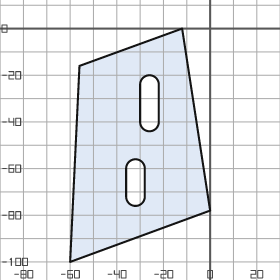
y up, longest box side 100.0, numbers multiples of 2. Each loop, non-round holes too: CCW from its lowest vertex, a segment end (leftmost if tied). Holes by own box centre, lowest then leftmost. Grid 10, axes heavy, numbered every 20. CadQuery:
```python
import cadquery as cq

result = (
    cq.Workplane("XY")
    .moveTo(-60.0, -100.0)
    .lineTo(0.0, -78.0)
    .lineTo(-12.0, 0.0)
    .lineTo(-56.0, -16.0)
    .close()
    .moveTo(-36.0, -72.0)
    .threePointArc((-32.0, -76.0), (-28.0, -72.0))
    .lineTo(-28.0, -60.0)
    .threePointArc((-32.0, -56.0), (-36.0, -60.0))
    .close()
    .moveTo(-30.0, -40.0)
    .threePointArc((-26.0, -44.0), (-22.0, -40.0))
    .lineTo(-22.0, -24.0)
    .threePointArc((-26.0, -20.0), (-30.0, -24.0))
    .close()
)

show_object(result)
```